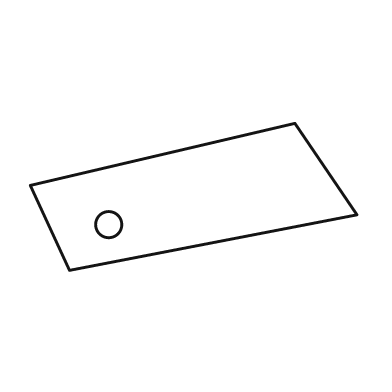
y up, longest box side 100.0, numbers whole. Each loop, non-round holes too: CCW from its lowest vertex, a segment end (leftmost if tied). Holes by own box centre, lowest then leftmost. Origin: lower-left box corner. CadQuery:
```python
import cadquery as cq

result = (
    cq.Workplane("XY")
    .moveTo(12.0, 0.0)
    .lineTo(100.0, 17.0)
    .lineTo(81.0, 45.0)
    .lineTo(0.0, 26.0)
    .close()
    .moveTo(24.0, 14.0)
    .circle(4.0)
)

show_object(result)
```